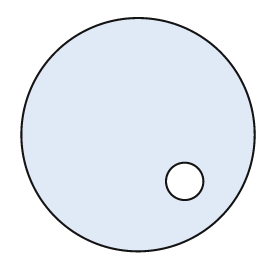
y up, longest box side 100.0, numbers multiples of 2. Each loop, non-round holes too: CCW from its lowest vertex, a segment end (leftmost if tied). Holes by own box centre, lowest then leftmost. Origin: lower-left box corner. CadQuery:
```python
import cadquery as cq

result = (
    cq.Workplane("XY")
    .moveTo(50.0, 50.0)
    .circle(50.0)
    .moveTo(70.0, 30.0)
    .circle(8.0)
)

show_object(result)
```